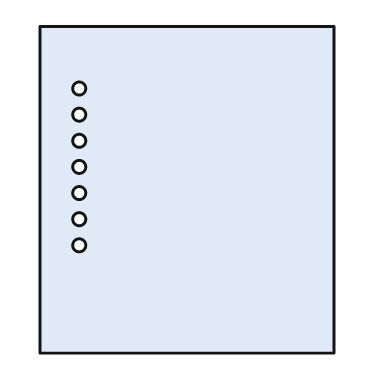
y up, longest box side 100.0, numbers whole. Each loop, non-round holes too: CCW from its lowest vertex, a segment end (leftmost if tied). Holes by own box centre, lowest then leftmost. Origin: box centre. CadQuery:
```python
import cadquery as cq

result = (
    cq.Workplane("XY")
    .moveTo(-45.0, -50.0)
    .lineTo(45.0, -50.0)
    .lineTo(45.0, 50.0)
    .lineTo(-45.0, 50.0)
    .close()
    .moveTo(-33.0, -17.0)
    .circle(2.0)
    .moveTo(-33.0, -9.0)
    .circle(2.0)
    .moveTo(-33.0, -1.0)
    .circle(2.0)
    .moveTo(-33.0, 7.0)
    .circle(2.0)
    .moveTo(-33.0, 15.0)
    .circle(2.0)
    .moveTo(-33.0, 23.0)
    .circle(2.0)
    .moveTo(-33.0, 31.0)
    .circle(2.0)
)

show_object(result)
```